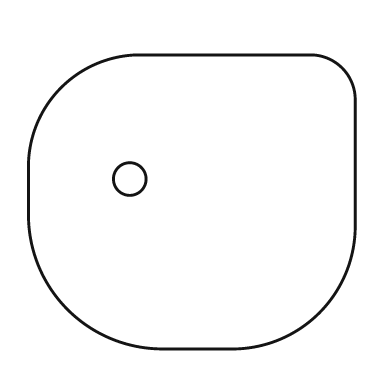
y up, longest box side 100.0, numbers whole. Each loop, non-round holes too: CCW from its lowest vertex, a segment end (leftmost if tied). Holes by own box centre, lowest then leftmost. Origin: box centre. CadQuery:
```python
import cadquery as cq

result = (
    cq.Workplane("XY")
    .moveTo(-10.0, -45.0)
    .lineTo(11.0, -45.0)
    .threePointArc((39.0, -34.0), (50.0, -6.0))
    .lineTo(50.0, 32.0)
    .threePointArc((46.0, 41.0), (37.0, 45.0))
    .lineTo(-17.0, 45.0)
    .threePointArc((-40.0, 35.0), (-50.0, 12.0))
    .lineTo(-50.0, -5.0)
    .threePointArc((-38.0, -33.0), (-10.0, -45.0))
    .close()
    .moveTo(-19.0, 7.0)
    .circle(5.0)
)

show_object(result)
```